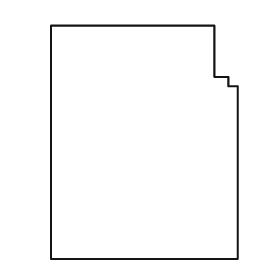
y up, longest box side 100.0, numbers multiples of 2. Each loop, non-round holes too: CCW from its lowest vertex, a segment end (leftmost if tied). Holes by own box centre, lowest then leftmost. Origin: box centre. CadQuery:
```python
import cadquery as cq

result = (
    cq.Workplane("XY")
    .moveTo(-40.0, -50.0)
    .lineTo(40.0, -50.0)
    .lineTo(40.0, 24.0)
    .lineTo(36.0, 24.0)
    .lineTo(36.0, 28.0)
    .lineTo(30.0, 28.0)
    .lineTo(30.0, 50.0)
    .lineTo(-40.0, 50.0)
    .close()
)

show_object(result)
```